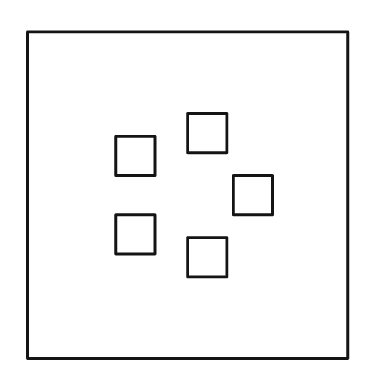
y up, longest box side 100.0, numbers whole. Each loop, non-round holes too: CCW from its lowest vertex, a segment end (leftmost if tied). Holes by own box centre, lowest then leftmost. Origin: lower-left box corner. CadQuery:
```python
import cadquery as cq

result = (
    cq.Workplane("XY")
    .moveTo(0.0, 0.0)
    .lineTo(98.0, 0.0)
    .lineTo(98.0, 100.0)
    .lineTo(0.0, 100.0)
    .close()
    .moveTo(49.0, 25.0)
    .lineTo(61.0, 25.0)
    .lineTo(61.0, 37.0)
    .lineTo(49.0, 37.0)
    .close()
    .moveTo(27.0, 32.0)
    .lineTo(39.0, 32.0)
    .lineTo(39.0, 44.0)
    .lineTo(27.0, 44.0)
    .close()
    .moveTo(63.0, 44.0)
    .lineTo(75.0, 44.0)
    .lineTo(75.0, 56.0)
    .lineTo(63.0, 56.0)
    .close()
    .moveTo(27.0, 56.0)
    .lineTo(39.0, 56.0)
    .lineTo(39.0, 68.0)
    .lineTo(27.0, 68.0)
    .close()
    .moveTo(49.0, 63.0)
    .lineTo(61.0, 63.0)
    .lineTo(61.0, 75.0)
    .lineTo(49.0, 75.0)
    .close()
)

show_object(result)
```